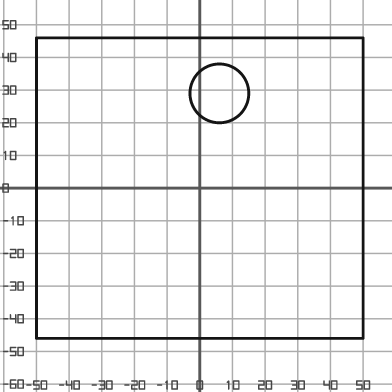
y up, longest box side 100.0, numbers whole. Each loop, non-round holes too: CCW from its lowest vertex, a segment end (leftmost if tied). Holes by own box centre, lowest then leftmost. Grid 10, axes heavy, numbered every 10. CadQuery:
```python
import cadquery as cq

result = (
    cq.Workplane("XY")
    .moveTo(-50.0, -46.0)
    .lineTo(50.0, -46.0)
    .lineTo(50.0, 46.0)
    .lineTo(-50.0, 46.0)
    .close()
    .moveTo(6.0, 29.0)
    .circle(9.0)
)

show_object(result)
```